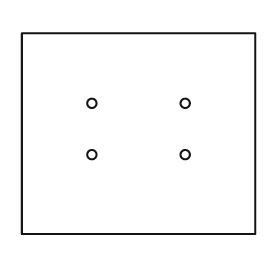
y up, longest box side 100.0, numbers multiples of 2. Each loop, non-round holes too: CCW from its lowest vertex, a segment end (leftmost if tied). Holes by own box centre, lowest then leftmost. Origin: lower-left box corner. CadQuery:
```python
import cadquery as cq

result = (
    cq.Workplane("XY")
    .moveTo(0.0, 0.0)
    .lineTo(100.0, 0.0)
    .lineTo(100.0, 86.0)
    .lineTo(0.0, 86.0)
    .close()
    .moveTo(30.0, 34.0)
    .circle(2.0)
    .moveTo(70.0, 34.0)
    .circle(2.0)
    .moveTo(30.0, 56.0)
    .circle(2.0)
    .moveTo(70.0, 56.0)
    .circle(2.0)
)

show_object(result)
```